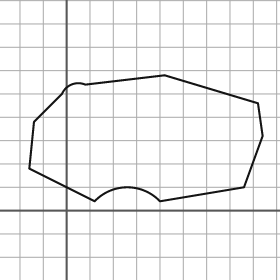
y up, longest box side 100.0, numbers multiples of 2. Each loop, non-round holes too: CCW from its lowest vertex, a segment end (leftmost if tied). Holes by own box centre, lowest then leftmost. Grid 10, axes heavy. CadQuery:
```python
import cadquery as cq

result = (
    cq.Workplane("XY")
    .moveTo(12.0, 4.0)
    .threePointArc((26.0, 10.0), (40.0, 4.0))
    .lineTo(76.0, 10.0)
    .lineTo(84.0, 32.0)
    .lineTo(82.0, 46.0)
    .lineTo(42.0, 58.0)
    .lineTo(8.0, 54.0)
    .threePointArc((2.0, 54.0), (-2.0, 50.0))
    .lineTo(-14.0, 38.0)
    .lineTo(-16.0, 18.0)
    .close()
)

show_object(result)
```